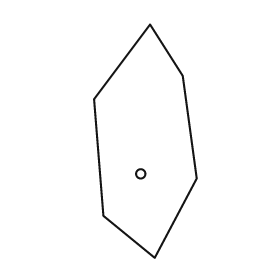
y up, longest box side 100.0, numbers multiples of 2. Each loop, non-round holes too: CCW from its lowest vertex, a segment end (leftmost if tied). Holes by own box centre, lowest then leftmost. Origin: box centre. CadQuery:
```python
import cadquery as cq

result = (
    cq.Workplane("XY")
    .moveTo(4.0, -50.0)
    .lineTo(22.0, -16.0)
    .lineTo(16.0, 28.0)
    .lineTo(2.0, 50.0)
    .lineTo(-22.0, 18.0)
    .lineTo(-18.0, -32.0)
    .close()
    .moveTo(-2.0, -14.0)
    .circle(2.0)
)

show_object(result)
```